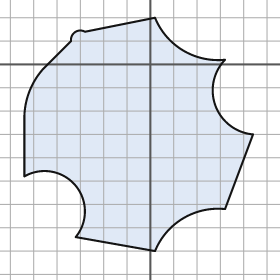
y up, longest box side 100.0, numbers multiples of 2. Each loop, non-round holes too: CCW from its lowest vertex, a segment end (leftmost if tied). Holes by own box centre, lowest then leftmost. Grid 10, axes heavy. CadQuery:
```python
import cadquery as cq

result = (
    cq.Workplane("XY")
    .moveTo(2.0, -80.0)
    .threePointArc((14.0, -66.0), (32.0, -62.0))
    .lineTo(44.0, -30.0)
    .threePointArc((28.0, -18.0), (32.0, 2.0))
    .threePointArc((14.0, 6.0), (2.0, 20.0))
    .lineTo(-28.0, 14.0)
    .threePointArc((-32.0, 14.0), (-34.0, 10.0))
    .lineTo(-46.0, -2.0)
    .threePointArc((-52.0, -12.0), (-54.0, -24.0))
    .lineTo(-54.0, -48.0)
    .threePointArc((-32.0, -52.0), (-32.0, -74.0))
    .close()
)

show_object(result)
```